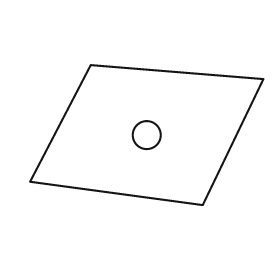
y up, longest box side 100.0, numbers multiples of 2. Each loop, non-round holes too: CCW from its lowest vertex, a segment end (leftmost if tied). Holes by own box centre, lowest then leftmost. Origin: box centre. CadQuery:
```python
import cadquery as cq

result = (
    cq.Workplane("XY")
    .moveTo(24.0, -30.0)
    .lineTo(50.0, 24.0)
    .lineTo(-24.0, 30.0)
    .lineTo(-50.0, -20.0)
    .close()
    .moveTo(0.0, 0.0)
    .circle(6.0)
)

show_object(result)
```